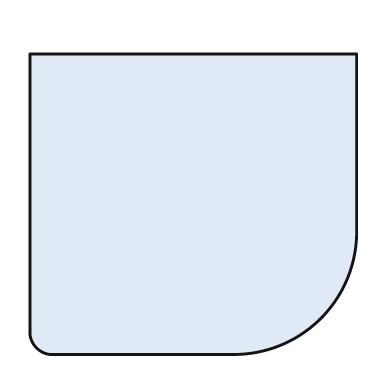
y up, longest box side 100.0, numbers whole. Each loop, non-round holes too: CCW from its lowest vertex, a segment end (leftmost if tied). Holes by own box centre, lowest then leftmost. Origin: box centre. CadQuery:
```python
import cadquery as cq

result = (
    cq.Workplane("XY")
    .moveTo(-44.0, -46.0)
    .lineTo(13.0, -46.0)
    .threePointArc((39.0, -35.0), (50.0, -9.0))
    .lineTo(50.0, 46.0)
    .lineTo(-50.0, 46.0)
    .lineTo(-50.0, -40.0)
    .threePointArc((-48.0, -44.0), (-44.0, -46.0))
    .close()
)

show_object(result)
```